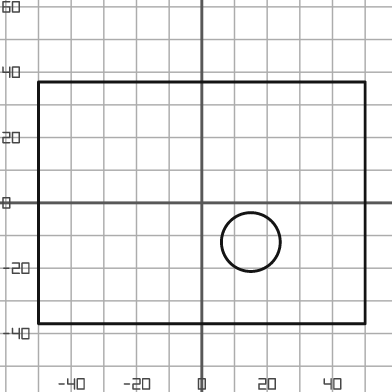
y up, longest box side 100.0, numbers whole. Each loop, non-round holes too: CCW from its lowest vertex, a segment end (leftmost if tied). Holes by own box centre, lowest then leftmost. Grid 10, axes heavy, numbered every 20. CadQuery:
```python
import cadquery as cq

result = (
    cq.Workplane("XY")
    .moveTo(-50.0, -37.0)
    .lineTo(50.0, -37.0)
    .lineTo(50.0, 37.0)
    .lineTo(-50.0, 37.0)
    .close()
    .moveTo(15.0, -12.0)
    .circle(9.0)
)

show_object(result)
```